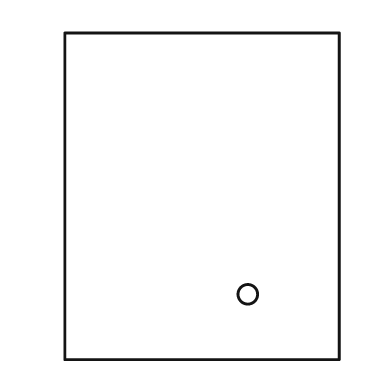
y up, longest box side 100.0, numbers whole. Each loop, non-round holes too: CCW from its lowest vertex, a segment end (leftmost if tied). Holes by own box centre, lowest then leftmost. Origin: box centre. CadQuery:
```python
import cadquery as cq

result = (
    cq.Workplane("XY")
    .moveTo(-42.0, -50.0)
    .lineTo(42.0, -50.0)
    .lineTo(42.0, 50.0)
    .lineTo(-42.0, 50.0)
    .close()
    .moveTo(14.0, -30.0)
    .circle(3.0)
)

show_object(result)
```